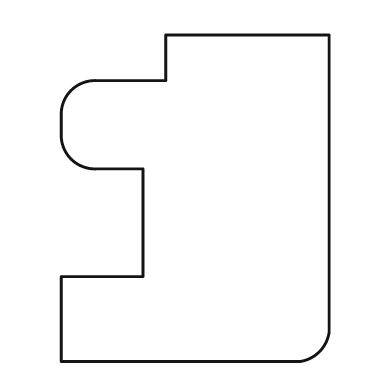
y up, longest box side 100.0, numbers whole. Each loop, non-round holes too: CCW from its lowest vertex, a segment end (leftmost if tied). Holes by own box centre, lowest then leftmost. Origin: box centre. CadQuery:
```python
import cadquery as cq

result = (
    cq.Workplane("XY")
    .moveTo(-41.0, -50.0)
    .lineTo(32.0, -50.0)
    .threePointArc((38.0, -47.0), (41.0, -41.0))
    .lineTo(41.0, 50.0)
    .lineTo(-9.0, 50.0)
    .lineTo(-9.0, 36.0)
    .lineTo(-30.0, 36.0)
    .threePointArc((-38.0, 33.0), (-41.0, 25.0))
    .lineTo(-41.0, 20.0)
    .threePointArc((-38.0, 12.0), (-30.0, 9.0))
    .lineTo(-16.0, 9.0)
    .lineTo(-16.0, -24.0)
    .lineTo(-41.0, -24.0)
    .close()
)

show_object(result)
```